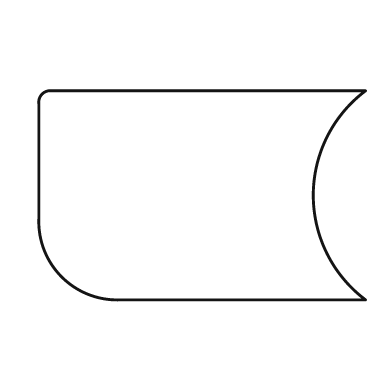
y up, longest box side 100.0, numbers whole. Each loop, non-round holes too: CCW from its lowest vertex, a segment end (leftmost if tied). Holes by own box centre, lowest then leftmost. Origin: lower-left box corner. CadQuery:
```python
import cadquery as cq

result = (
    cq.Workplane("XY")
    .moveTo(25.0, 0.0)
    .lineTo(100.0, 0.0)
    .threePointArc((84.0, 32.0), (100.0, 64.0))
    .lineTo(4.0, 64.0)
    .threePointArc((1.0, 63.0), (0.0, 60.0))
    .lineTo(0.0, 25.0)
    .threePointArc((7.0, 7.0), (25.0, 0.0))
    .close()
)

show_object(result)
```